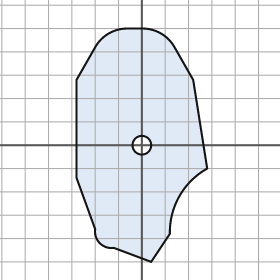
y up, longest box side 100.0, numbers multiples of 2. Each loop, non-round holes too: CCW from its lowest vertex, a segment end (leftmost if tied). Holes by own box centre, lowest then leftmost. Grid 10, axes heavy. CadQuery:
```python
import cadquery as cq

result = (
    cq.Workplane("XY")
    .moveTo(4.0, -50.0)
    .lineTo(12.0, -38.0)
    .threePointArc((16.0, -22.0), (28.0, -10.0))
    .lineTo(22.0, 28.0)
    .lineTo(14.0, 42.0)
    .threePointArc((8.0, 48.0), (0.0, 50.0))
    .lineTo(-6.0, 50.0)
    .threePointArc((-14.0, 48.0), (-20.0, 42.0))
    .lineTo(-28.0, 28.0)
    .lineTo(-28.0, -14.0)
    .lineTo(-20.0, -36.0)
    .threePointArc((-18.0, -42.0), (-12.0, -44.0))
    .close()
    .moveTo(0.0, 0.0)
    .circle(4.0)
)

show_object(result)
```